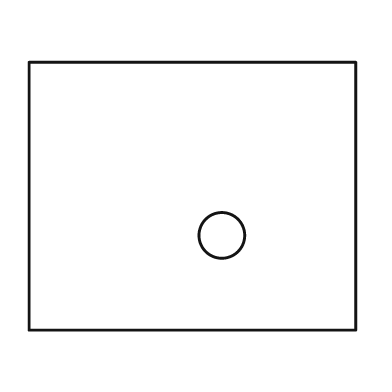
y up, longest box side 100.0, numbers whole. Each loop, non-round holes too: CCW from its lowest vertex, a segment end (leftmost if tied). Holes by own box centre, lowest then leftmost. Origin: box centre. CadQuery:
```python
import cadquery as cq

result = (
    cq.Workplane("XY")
    .moveTo(-50.0, -41.0)
    .lineTo(50.0, -41.0)
    .lineTo(50.0, 41.0)
    .lineTo(-50.0, 41.0)
    .close()
    .moveTo(9.0, -12.0)
    .circle(7.0)
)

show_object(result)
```